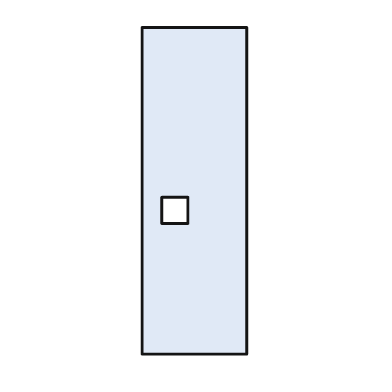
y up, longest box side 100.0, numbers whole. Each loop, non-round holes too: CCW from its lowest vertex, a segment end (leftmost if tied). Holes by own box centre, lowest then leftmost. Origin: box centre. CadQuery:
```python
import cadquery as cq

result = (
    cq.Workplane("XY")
    .moveTo(-16.0, -50.0)
    .lineTo(16.0, -50.0)
    .lineTo(16.0, 50.0)
    .lineTo(-16.0, 50.0)
    .close()
    .moveTo(-10.0, -10.0)
    .lineTo(-2.0, -10.0)
    .lineTo(-2.0, -2.0)
    .lineTo(-10.0, -2.0)
    .close()
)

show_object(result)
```